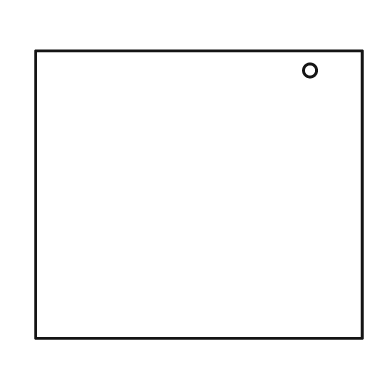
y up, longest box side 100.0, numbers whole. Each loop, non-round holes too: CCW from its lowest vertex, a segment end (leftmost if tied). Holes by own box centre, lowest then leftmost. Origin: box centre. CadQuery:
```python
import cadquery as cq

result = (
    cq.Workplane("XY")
    .moveTo(-50.0, -44.0)
    .lineTo(50.0, -44.0)
    .lineTo(50.0, 44.0)
    .lineTo(-50.0, 44.0)
    .close()
    .moveTo(34.0, 38.0)
    .circle(2.0)
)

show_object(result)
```